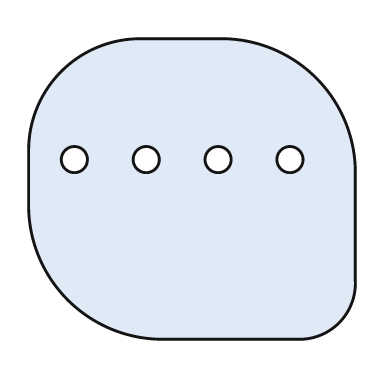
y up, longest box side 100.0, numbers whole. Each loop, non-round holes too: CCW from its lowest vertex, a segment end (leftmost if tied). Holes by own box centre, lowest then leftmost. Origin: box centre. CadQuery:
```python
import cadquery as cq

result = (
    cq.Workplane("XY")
    .moveTo(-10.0, -46.0)
    .lineTo(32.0, -46.0)
    .threePointArc((45.0, -41.0), (50.0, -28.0))
    .lineTo(50.0, 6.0)
    .threePointArc((38.0, 34.0), (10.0, 46.0))
    .lineTo(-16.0, 46.0)
    .threePointArc((-40.0, 36.0), (-50.0, 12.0))
    .lineTo(-50.0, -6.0)
    .threePointArc((-38.0, -34.0), (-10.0, -46.0))
    .close()
    .moveTo(-36.0, 9.0)
    .circle(4.0)
    .moveTo(-14.0, 9.0)
    .circle(4.0)
    .moveTo(8.0, 9.0)
    .circle(4.0)
    .moveTo(30.0, 9.0)
    .circle(4.0)
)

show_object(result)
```